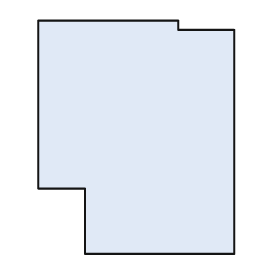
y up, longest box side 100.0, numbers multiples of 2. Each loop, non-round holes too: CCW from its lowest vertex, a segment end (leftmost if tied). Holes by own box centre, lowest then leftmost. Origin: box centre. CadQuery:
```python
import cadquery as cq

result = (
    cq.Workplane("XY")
    .moveTo(-22.0, -50.0)
    .lineTo(42.0, -50.0)
    .lineTo(42.0, 46.0)
    .lineTo(18.0, 46.0)
    .lineTo(18.0, 50.0)
    .lineTo(-42.0, 50.0)
    .lineTo(-42.0, -22.0)
    .lineTo(-22.0, -22.0)
    .close()
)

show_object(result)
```